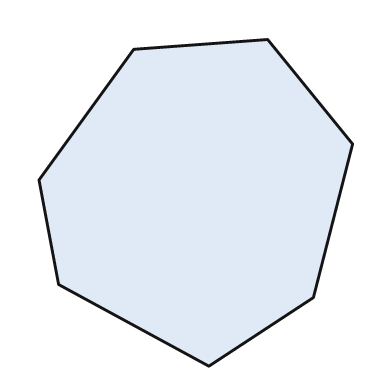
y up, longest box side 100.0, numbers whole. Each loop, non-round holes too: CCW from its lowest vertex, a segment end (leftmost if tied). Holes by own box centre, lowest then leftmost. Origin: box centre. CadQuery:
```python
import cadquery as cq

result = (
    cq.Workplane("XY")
    .moveTo(4.0, -50.0)
    .lineTo(36.0, -29.0)
    .lineTo(48.0, 18.0)
    .lineTo(22.0, 50.0)
    .lineTo(-19.0, 47.0)
    .lineTo(-48.0, 7.0)
    .lineTo(-42.0, -25.0)
    .close()
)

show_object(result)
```